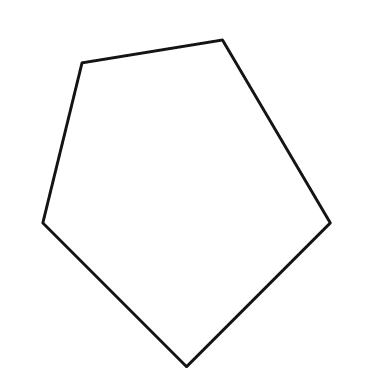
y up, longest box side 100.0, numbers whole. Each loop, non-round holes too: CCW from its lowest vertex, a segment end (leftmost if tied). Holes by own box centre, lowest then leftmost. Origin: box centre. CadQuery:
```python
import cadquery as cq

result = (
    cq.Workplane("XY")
    .moveTo(0.0, -50.0)
    .lineTo(44.0, -6.0)
    .lineTo(11.0, 50.0)
    .lineTo(-32.0, 43.0)
    .lineTo(-44.0, -6.0)
    .close()
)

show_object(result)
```